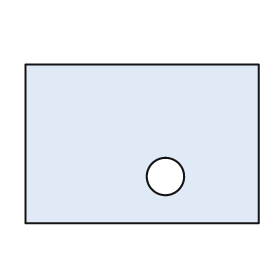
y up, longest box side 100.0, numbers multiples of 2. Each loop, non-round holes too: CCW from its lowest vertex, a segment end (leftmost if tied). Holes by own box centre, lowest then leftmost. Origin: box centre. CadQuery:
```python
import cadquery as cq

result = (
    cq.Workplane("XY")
    .moveTo(-50.0, -34.0)
    .lineTo(50.0, -34.0)
    .lineTo(50.0, 34.0)
    .lineTo(-50.0, 34.0)
    .close()
    .moveTo(10.0, -14.0)
    .circle(8.0)
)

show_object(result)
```